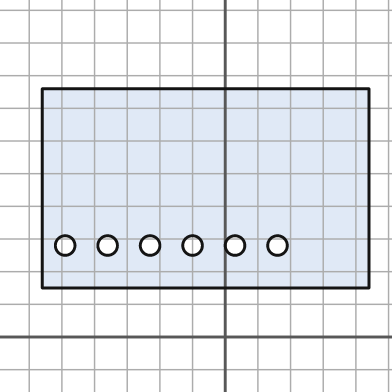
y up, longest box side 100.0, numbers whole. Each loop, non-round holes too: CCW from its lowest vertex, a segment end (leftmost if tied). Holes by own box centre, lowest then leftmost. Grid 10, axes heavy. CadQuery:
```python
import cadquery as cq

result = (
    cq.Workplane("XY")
    .moveTo(-56.0, 15.0)
    .lineTo(44.0, 15.0)
    .lineTo(44.0, 76.0)
    .lineTo(-56.0, 76.0)
    .close()
    .moveTo(-49.0, 28.0)
    .circle(3.0)
    .moveTo(-36.0, 28.0)
    .circle(3.0)
    .moveTo(-23.0, 28.0)
    .circle(3.0)
    .moveTo(-10.0, 28.0)
    .circle(3.0)
    .moveTo(3.0, 28.0)
    .circle(3.0)
    .moveTo(16.0, 28.0)
    .circle(3.0)
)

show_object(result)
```